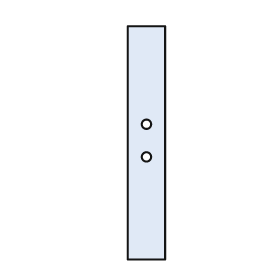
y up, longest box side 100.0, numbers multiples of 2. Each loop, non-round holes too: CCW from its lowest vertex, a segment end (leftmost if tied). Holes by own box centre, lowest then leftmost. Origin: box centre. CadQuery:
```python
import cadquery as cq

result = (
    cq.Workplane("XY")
    .moveTo(-8.0, -50.0)
    .lineTo(8.0, -50.0)
    .lineTo(8.0, 50.0)
    .lineTo(-8.0, 50.0)
    .close()
    .moveTo(0.0, -6.0)
    .circle(2.0)
    .moveTo(0.0, 8.0)
    .circle(2.0)
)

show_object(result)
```